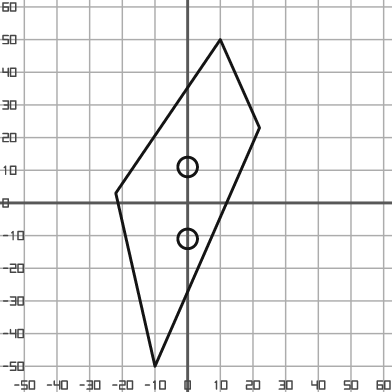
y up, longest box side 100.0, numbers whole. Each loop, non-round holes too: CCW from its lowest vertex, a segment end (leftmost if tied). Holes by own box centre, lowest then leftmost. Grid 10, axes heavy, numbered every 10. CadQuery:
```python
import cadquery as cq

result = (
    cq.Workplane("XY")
    .moveTo(-10.0, -50.0)
    .lineTo(22.0, 23.0)
    .lineTo(10.0, 50.0)
    .lineTo(-22.0, 3.0)
    .close()
    .moveTo(0.0, -11.0)
    .circle(3.0)
    .moveTo(0.0, 11.0)
    .circle(3.0)
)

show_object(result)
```